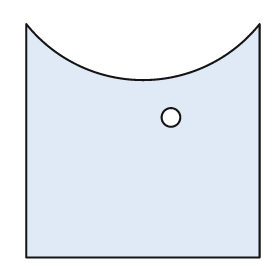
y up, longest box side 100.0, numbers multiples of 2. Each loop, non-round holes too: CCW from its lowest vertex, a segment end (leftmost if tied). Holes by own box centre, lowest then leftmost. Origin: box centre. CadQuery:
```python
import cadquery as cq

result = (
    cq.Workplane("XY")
    .moveTo(-50.0, -50.0)
    .lineTo(50.0, -50.0)
    .lineTo(50.0, 50.0)
    .threePointArc((0.0, 26.0), (-50.0, 50.0))
    .close()
    .moveTo(12.0, 10.0)
    .circle(4.0)
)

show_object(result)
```